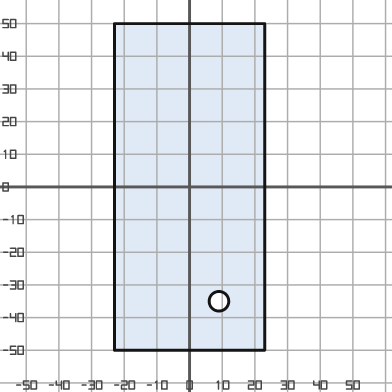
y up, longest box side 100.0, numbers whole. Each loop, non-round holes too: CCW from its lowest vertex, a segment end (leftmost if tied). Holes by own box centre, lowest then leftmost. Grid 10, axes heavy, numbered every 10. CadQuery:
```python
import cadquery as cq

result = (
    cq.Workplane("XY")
    .moveTo(-23.0, -50.0)
    .lineTo(23.0, -50.0)
    .lineTo(23.0, 50.0)
    .lineTo(-23.0, 50.0)
    .close()
    .moveTo(9.0, -35.0)
    .circle(3.0)
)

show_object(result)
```